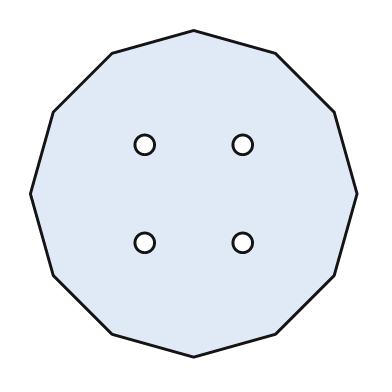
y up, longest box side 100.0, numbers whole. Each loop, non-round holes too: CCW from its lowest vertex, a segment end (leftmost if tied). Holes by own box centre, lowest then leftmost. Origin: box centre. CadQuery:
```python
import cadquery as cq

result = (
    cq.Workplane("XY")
    .moveTo(0.0, -50.0)
    .lineTo(25.0, -43.0)
    .lineTo(43.0, -25.0)
    .lineTo(50.0, 0.0)
    .lineTo(43.0, 25.0)
    .lineTo(25.0, 43.0)
    .lineTo(0.0, 50.0)
    .lineTo(-25.0, 43.0)
    .lineTo(-43.0, 25.0)
    .lineTo(-50.0, 0.0)
    .lineTo(-43.0, -25.0)
    .lineTo(-25.0, -43.0)
    .close()
    .moveTo(-15.0, -15.0)
    .circle(3.0)
    .moveTo(15.0, -15.0)
    .circle(3.0)
    .moveTo(-15.0, 15.0)
    .circle(3.0)
    .moveTo(15.0, 15.0)
    .circle(3.0)
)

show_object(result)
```